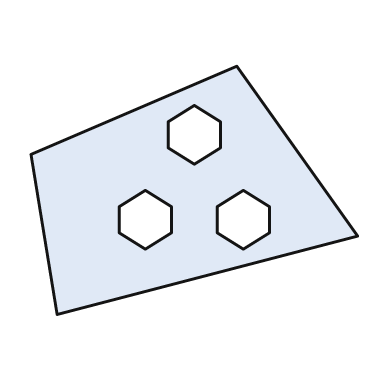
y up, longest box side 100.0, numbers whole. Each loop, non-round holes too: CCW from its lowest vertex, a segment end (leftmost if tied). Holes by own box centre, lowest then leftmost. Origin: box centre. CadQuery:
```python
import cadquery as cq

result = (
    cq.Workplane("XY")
    .moveTo(-42.0, -38.0)
    .lineTo(50.0, -14.0)
    .lineTo(13.0, 38.0)
    .lineTo(-50.0, 11.0)
    .close()
    .moveTo(-15.0, -18.0)
    .lineTo(-7.0, -13.0)
    .lineTo(-7.0, -5.0)
    .lineTo(-15.0, 0.0)
    .lineTo(-23.0, -5.0)
    .lineTo(-23.0, -13.0)
    .close()
    .moveTo(15.0, -18.0)
    .lineTo(23.0, -13.0)
    .lineTo(23.0, -5.0)
    .lineTo(15.0, 0.0)
    .lineTo(7.0, -5.0)
    .lineTo(7.0, -13.0)
    .close()
    .moveTo(0.0, 8.0)
    .lineTo(8.0, 13.0)
    .lineTo(8.0, 21.0)
    .lineTo(0.0, 26.0)
    .lineTo(-8.0, 21.0)
    .lineTo(-8.0, 13.0)
    .close()
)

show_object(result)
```